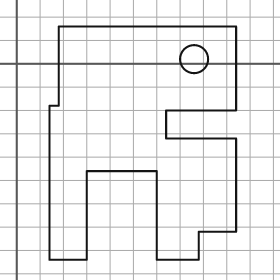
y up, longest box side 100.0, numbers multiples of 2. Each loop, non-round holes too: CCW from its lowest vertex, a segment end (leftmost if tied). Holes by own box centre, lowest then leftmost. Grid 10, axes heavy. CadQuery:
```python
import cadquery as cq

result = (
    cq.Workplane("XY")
    .moveTo(14.0, -84.0)
    .lineTo(30.0, -84.0)
    .lineTo(30.0, -46.0)
    .lineTo(60.0, -46.0)
    .lineTo(60.0, -84.0)
    .lineTo(78.0, -84.0)
    .lineTo(78.0, -72.0)
    .lineTo(94.0, -72.0)
    .lineTo(94.0, -32.0)
    .lineTo(64.0, -32.0)
    .lineTo(64.0, -20.0)
    .lineTo(94.0, -20.0)
    .lineTo(94.0, 16.0)
    .lineTo(18.0, 16.0)
    .lineTo(18.0, -18.0)
    .lineTo(14.0, -18.0)
    .close()
    .moveTo(76.0, 2.0)
    .circle(6.0)
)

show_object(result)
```